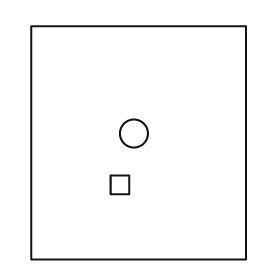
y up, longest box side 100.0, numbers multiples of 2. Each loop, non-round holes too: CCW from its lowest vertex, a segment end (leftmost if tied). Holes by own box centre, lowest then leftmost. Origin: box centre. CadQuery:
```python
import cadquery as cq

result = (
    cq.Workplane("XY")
    .moveTo(-46.0, -50.0)
    .lineTo(46.0, -50.0)
    .lineTo(46.0, 50.0)
    .lineTo(-46.0, 50.0)
    .close()
    .moveTo(-12.0, -22.0)
    .lineTo(-4.0, -22.0)
    .lineTo(-4.0, -14.0)
    .lineTo(-12.0, -14.0)
    .close()
    .moveTo(-2.0, 4.0)
    .circle(6.0)
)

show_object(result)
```